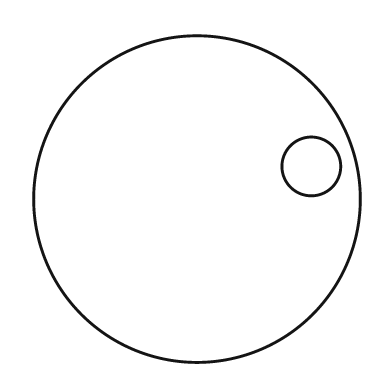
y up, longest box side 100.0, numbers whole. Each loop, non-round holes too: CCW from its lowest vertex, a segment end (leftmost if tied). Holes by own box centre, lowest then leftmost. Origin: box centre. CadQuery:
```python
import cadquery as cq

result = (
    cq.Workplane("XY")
    .moveTo(0.0, 0.0)
    .circle(50.0)
    .moveTo(35.0, 10.0)
    .circle(9.0)
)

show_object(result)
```